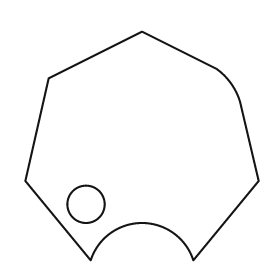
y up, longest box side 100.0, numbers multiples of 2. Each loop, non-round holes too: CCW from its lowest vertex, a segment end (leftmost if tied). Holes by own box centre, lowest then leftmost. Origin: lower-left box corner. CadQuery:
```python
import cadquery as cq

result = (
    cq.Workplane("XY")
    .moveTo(28.0, 0.0)
    .threePointArc((50.0, 16.0), (72.0, 0.0))
    .lineTo(100.0, 34.0)
    .lineTo(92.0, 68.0)
    .threePointArc((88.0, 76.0), (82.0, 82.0))
    .lineTo(50.0, 98.0)
    .lineTo(10.0, 78.0)
    .lineTo(0.0, 34.0)
    .close()
    .moveTo(26.0, 24.0)
    .circle(8.0)
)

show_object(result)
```